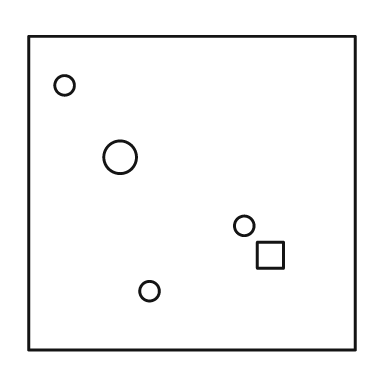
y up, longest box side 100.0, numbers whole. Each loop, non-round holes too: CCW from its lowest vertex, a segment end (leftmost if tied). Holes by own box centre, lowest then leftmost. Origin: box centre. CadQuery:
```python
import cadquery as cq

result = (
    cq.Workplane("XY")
    .moveTo(-50.0, -48.0)
    .lineTo(50.0, -48.0)
    .lineTo(50.0, 48.0)
    .lineTo(-50.0, 48.0)
    .close()
    .moveTo(-13.0, -30.0)
    .circle(3.0)
    .moveTo(20.0, -23.0)
    .lineTo(28.0, -23.0)
    .lineTo(28.0, -15.0)
    .lineTo(20.0, -15.0)
    .close()
    .moveTo(16.0, -10.0)
    .circle(3.0)
    .moveTo(-22.0, 11.0)
    .circle(5.0)
    .moveTo(-39.0, 33.0)
    .circle(3.0)
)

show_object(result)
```